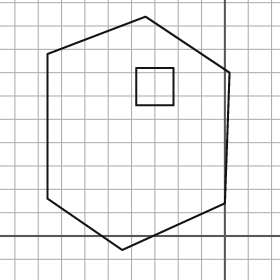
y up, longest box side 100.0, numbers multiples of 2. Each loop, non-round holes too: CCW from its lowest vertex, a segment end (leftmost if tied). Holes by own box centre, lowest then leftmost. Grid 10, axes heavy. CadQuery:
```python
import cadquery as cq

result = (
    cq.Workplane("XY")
    .moveTo(-44.0, -6.0)
    .lineTo(0.0, 14.0)
    .lineTo(2.0, 70.0)
    .lineTo(-34.0, 94.0)
    .lineTo(-76.0, 78.0)
    .lineTo(-76.0, 16.0)
    .close()
    .moveTo(-38.0, 56.0)
    .lineTo(-22.0, 56.0)
    .lineTo(-22.0, 72.0)
    .lineTo(-38.0, 72.0)
    .close()
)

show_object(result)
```